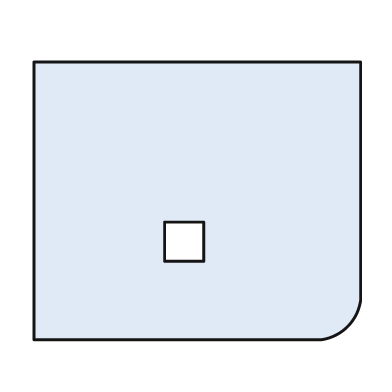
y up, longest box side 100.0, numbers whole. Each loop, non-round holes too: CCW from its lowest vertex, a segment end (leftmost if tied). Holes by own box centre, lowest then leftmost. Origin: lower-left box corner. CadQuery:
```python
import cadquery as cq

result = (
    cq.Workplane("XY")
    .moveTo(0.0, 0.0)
    .lineTo(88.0, 0.0)
    .threePointArc((96.0, 4.0), (100.0, 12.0))
    .lineTo(100.0, 85.0)
    .lineTo(0.0, 85.0)
    .close()
    .moveTo(40.0, 24.0)
    .lineTo(52.0, 24.0)
    .lineTo(52.0, 36.0)
    .lineTo(40.0, 36.0)
    .close()
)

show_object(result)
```